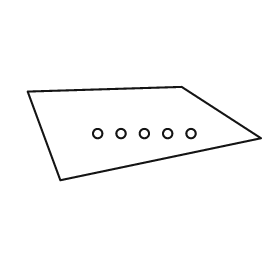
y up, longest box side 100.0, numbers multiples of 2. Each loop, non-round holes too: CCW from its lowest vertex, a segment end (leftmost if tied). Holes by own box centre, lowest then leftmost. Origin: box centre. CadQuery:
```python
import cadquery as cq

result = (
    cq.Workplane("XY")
    .moveTo(-36.0, -20.0)
    .lineTo(50.0, -2.0)
    .lineTo(16.0, 20.0)
    .lineTo(-50.0, 18.0)
    .close()
    .moveTo(-20.0, 0.0)
    .circle(2.0)
    .moveTo(-10.0, 0.0)
    .circle(2.0)
    .moveTo(0.0, 0.0)
    .circle(2.0)
    .moveTo(10.0, 0.0)
    .circle(2.0)
    .moveTo(20.0, 0.0)
    .circle(2.0)
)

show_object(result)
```